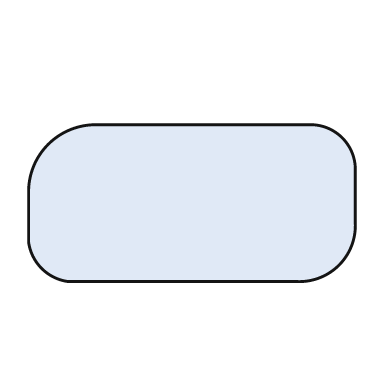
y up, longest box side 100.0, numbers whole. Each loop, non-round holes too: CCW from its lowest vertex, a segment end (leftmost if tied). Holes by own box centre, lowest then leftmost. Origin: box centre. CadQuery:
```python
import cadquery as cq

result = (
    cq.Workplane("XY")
    .moveTo(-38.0, -24.0)
    .lineTo(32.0, -24.0)
    .threePointArc((45.0, -19.0), (50.0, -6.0))
    .lineTo(50.0, 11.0)
    .threePointArc((46.0, 20.0), (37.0, 24.0))
    .lineTo(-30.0, 24.0)
    .threePointArc((-44.0, 18.0), (-50.0, 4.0))
    .lineTo(-50.0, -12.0)
    .threePointArc((-46.0, -20.0), (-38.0, -24.0))
    .close()
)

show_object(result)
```